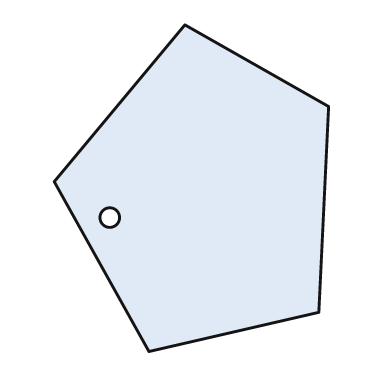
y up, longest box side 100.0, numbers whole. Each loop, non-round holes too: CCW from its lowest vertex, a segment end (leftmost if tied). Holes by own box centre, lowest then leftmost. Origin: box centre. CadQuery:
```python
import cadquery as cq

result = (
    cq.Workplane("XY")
    .moveTo(-13.0, -50.0)
    .lineTo(39.0, -38.0)
    .lineTo(42.0, 25.0)
    .lineTo(-2.0, 50.0)
    .lineTo(-42.0, 2.0)
    .close()
    .moveTo(-25.0, -9.0)
    .circle(3.0)
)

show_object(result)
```